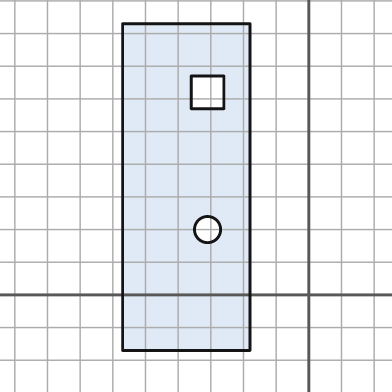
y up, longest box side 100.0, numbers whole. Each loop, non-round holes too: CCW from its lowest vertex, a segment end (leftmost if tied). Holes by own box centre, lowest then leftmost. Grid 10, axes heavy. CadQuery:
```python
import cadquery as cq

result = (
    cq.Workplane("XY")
    .moveTo(-57.0, -17.0)
    .lineTo(-18.0, -17.0)
    .lineTo(-18.0, 83.0)
    .lineTo(-57.0, 83.0)
    .close()
    .moveTo(-31.0, 20.0)
    .circle(4.0)
    .moveTo(-36.0, 57.0)
    .lineTo(-26.0, 57.0)
    .lineTo(-26.0, 67.0)
    .lineTo(-36.0, 67.0)
    .close()
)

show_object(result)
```